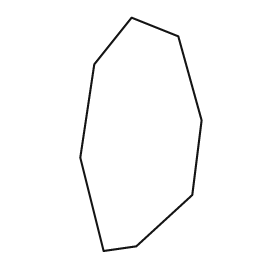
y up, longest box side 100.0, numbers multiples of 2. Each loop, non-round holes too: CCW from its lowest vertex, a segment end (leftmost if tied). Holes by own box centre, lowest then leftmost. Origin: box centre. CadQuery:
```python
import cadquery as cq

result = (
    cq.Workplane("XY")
    .moveTo(-16.0, -50.0)
    .lineTo(-2.0, -48.0)
    .lineTo(22.0, -26.0)
    .lineTo(26.0, 6.0)
    .lineTo(16.0, 42.0)
    .lineTo(-4.0, 50.0)
    .lineTo(-20.0, 30.0)
    .lineTo(-26.0, -10.0)
    .close()
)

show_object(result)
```